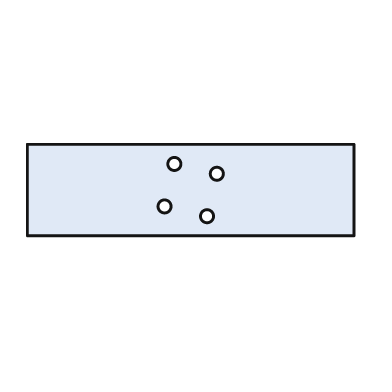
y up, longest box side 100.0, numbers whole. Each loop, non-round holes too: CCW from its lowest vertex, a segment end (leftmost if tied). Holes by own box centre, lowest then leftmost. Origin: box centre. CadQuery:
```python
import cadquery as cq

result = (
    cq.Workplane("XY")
    .moveTo(-50.0, -14.0)
    .lineTo(50.0, -14.0)
    .lineTo(50.0, 14.0)
    .lineTo(-50.0, 14.0)
    .close()
    .moveTo(5.0, -8.0)
    .circle(2.0)
    .moveTo(-8.0, -5.0)
    .circle(2.0)
    .moveTo(8.0, 5.0)
    .circle(2.0)
    .moveTo(-5.0, 8.0)
    .circle(2.0)
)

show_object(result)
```